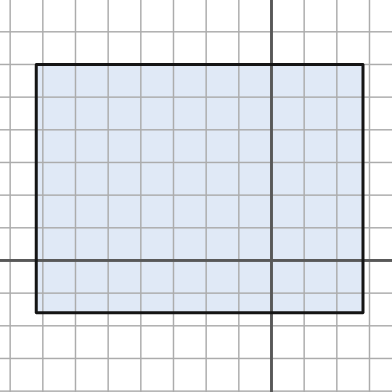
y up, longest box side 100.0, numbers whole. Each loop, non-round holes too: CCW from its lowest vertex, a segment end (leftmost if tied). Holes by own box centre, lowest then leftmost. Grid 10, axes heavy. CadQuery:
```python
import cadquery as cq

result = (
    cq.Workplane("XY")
    .moveTo(-72.0, -16.0)
    .lineTo(28.0, -16.0)
    .lineTo(28.0, 60.0)
    .lineTo(-72.0, 60.0)
    .close()
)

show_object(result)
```